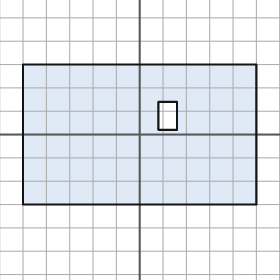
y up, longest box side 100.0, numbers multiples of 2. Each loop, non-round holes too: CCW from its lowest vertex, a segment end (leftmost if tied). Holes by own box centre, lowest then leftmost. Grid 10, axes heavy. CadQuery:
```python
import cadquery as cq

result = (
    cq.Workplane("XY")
    .moveTo(-50.0, -30.0)
    .lineTo(50.0, -30.0)
    .lineTo(50.0, 30.0)
    .lineTo(-50.0, 30.0)
    .close()
    .moveTo(8.0, 2.0)
    .lineTo(16.0, 2.0)
    .lineTo(16.0, 14.0)
    .lineTo(8.0, 14.0)
    .close()
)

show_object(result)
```